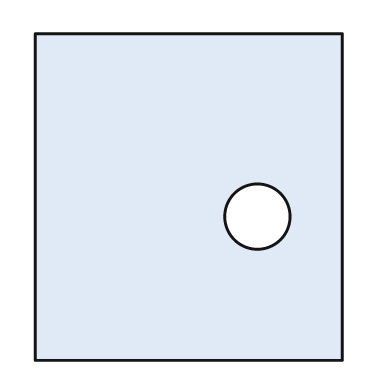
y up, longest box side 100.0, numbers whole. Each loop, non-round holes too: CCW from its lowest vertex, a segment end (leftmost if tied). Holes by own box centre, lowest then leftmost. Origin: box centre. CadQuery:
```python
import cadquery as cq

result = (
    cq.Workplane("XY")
    .moveTo(-47.0, -50.0)
    .lineTo(47.0, -50.0)
    .lineTo(47.0, 50.0)
    .lineTo(-47.0, 50.0)
    .close()
    .moveTo(21.0, -6.0)
    .circle(10.0)
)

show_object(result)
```